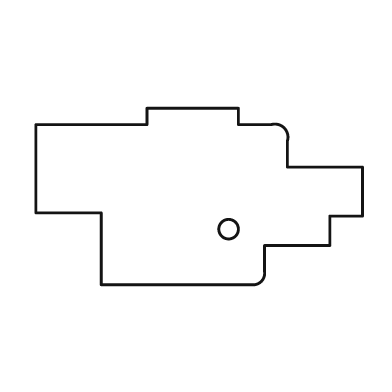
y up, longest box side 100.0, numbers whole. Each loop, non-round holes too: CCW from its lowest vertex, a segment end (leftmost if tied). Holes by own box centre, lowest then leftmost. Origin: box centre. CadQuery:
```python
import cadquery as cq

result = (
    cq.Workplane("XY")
    .moveTo(-30.0, -27.0)
    .lineTo(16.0, -27.0)
    .threePointArc((19.0, -26.0), (20.0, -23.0))
    .lineTo(20.0, -15.0)
    .lineTo(40.0, -15.0)
    .lineTo(40.0, -6.0)
    .lineTo(50.0, -6.0)
    .lineTo(50.0, 9.0)
    .lineTo(27.0, 9.0)
    .lineTo(27.0, 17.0)
    .threePointArc((26.0, 21.0), (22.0, 22.0))
    .lineTo(12.0, 22.0)
    .lineTo(12.0, 27.0)
    .lineTo(-16.0, 27.0)
    .lineTo(-16.0, 22.0)
    .lineTo(-50.0, 22.0)
    .lineTo(-50.0, -5.0)
    .lineTo(-30.0, -5.0)
    .close()
    .moveTo(9.0, -10.0)
    .circle(3.0)
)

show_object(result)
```